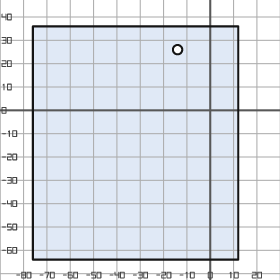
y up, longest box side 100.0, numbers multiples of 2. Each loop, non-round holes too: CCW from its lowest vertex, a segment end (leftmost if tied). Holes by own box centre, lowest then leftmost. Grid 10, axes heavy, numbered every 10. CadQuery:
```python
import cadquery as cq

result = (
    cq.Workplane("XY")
    .moveTo(-76.0, -64.0)
    .lineTo(12.0, -64.0)
    .lineTo(12.0, 36.0)
    .lineTo(-76.0, 36.0)
    .close()
    .moveTo(-14.0, 26.0)
    .circle(2.0)
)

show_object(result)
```